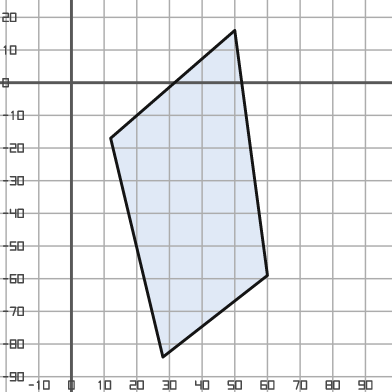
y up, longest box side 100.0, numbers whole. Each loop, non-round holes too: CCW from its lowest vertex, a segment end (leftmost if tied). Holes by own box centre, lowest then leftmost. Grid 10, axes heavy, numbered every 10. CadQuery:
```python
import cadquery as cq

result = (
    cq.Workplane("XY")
    .moveTo(28.0, -84.0)
    .lineTo(60.0, -59.0)
    .lineTo(50.0, 16.0)
    .lineTo(12.0, -17.0)
    .close()
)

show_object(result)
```